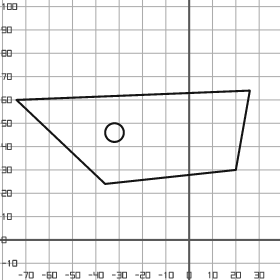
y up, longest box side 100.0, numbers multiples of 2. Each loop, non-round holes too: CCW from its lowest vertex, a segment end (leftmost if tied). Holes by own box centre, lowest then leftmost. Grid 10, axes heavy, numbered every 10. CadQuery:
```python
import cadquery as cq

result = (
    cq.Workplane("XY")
    .moveTo(-36.0, 24.0)
    .lineTo(20.0, 30.0)
    .lineTo(26.0, 64.0)
    .lineTo(-74.0, 60.0)
    .close()
    .moveTo(-32.0, 46.0)
    .circle(4.0)
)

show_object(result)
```